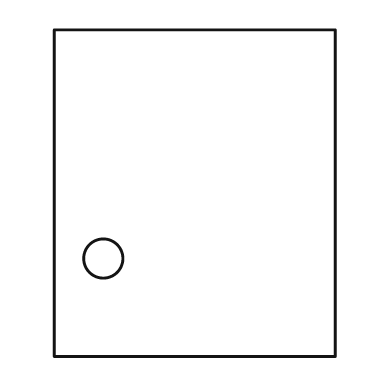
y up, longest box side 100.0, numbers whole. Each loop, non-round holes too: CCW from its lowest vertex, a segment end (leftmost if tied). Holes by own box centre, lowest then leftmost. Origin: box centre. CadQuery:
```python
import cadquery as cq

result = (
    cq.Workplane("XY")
    .moveTo(-43.0, -50.0)
    .lineTo(43.0, -50.0)
    .lineTo(43.0, 50.0)
    .lineTo(-43.0, 50.0)
    .close()
    .moveTo(-28.0, -20.0)
    .circle(6.0)
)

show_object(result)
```